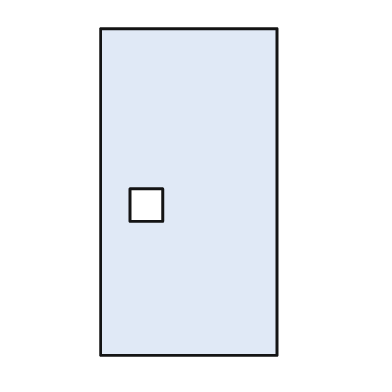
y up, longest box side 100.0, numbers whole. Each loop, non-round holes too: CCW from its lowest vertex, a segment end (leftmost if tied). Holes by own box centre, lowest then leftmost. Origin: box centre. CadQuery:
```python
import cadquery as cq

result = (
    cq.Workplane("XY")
    .moveTo(-27.0, -50.0)
    .lineTo(27.0, -50.0)
    .lineTo(27.0, 50.0)
    .lineTo(-27.0, 50.0)
    .close()
    .moveTo(-18.0, -9.0)
    .lineTo(-8.0, -9.0)
    .lineTo(-8.0, 1.0)
    .lineTo(-18.0, 1.0)
    .close()
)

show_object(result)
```